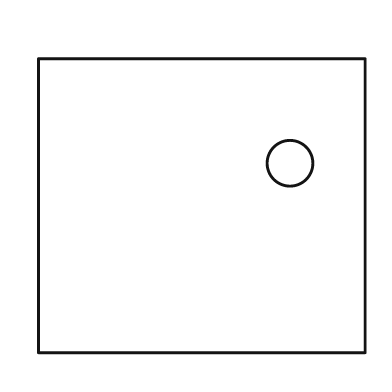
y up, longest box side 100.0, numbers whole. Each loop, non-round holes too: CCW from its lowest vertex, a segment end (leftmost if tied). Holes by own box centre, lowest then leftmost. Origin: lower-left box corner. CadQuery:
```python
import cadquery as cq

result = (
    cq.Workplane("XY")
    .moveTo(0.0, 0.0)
    .lineTo(100.0, 0.0)
    .lineTo(100.0, 90.0)
    .lineTo(0.0, 90.0)
    .close()
    .moveTo(77.0, 58.0)
    .circle(7.0)
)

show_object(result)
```